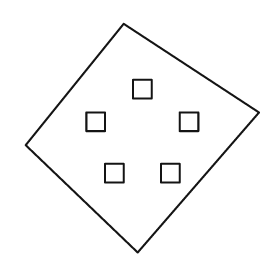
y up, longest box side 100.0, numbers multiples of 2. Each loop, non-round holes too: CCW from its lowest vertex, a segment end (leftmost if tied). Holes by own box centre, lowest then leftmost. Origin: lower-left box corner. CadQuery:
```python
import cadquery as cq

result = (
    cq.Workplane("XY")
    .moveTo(48.0, 0.0)
    .lineTo(100.0, 60.0)
    .lineTo(42.0, 98.0)
    .lineTo(0.0, 46.0)
    .close()
    .moveTo(34.0, 30.0)
    .lineTo(42.0, 30.0)
    .lineTo(42.0, 38.0)
    .lineTo(34.0, 38.0)
    .close()
    .moveTo(58.0, 30.0)
    .lineTo(66.0, 30.0)
    .lineTo(66.0, 38.0)
    .lineTo(58.0, 38.0)
    .close()
    .moveTo(26.0, 52.0)
    .lineTo(34.0, 52.0)
    .lineTo(34.0, 60.0)
    .lineTo(26.0, 60.0)
    .close()
    .moveTo(66.0, 52.0)
    .lineTo(74.0, 52.0)
    .lineTo(74.0, 60.0)
    .lineTo(66.0, 60.0)
    .close()
    .moveTo(46.0, 66.0)
    .lineTo(54.0, 66.0)
    .lineTo(54.0, 74.0)
    .lineTo(46.0, 74.0)
    .close()
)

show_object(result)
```